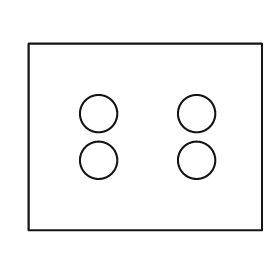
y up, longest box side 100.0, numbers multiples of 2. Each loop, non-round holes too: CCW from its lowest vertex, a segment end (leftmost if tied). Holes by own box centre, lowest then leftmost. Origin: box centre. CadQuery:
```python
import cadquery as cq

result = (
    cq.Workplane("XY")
    .moveTo(-50.0, -40.0)
    .lineTo(50.0, -40.0)
    .lineTo(50.0, 40.0)
    .lineTo(-50.0, 40.0)
    .close()
    .moveTo(-20.0, -10.0)
    .circle(8.0)
    .moveTo(22.0, -10.0)
    .circle(8.0)
    .moveTo(-20.0, 10.0)
    .circle(8.0)
    .moveTo(22.0, 10.0)
    .circle(8.0)
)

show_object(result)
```